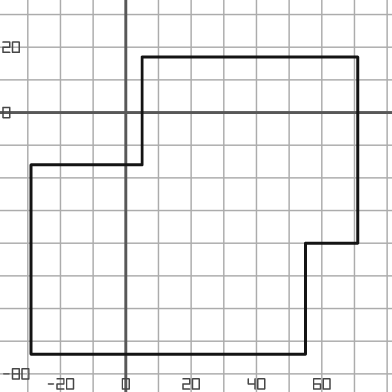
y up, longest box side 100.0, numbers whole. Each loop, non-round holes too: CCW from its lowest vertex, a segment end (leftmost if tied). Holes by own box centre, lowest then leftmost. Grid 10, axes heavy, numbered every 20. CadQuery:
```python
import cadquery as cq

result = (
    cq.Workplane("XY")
    .moveTo(-29.0, -74.0)
    .lineTo(55.0, -74.0)
    .lineTo(55.0, -40.0)
    .lineTo(71.0, -40.0)
    .lineTo(71.0, 17.0)
    .lineTo(5.0, 17.0)
    .lineTo(5.0, -16.0)
    .lineTo(-29.0, -16.0)
    .close()
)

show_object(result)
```